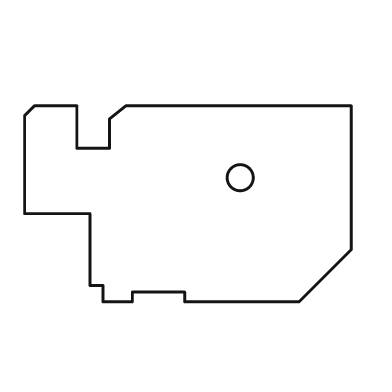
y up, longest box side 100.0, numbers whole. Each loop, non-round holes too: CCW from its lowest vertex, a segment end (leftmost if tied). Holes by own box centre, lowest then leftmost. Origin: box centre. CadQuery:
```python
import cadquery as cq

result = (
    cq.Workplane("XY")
    .moveTo(-26.0, -30.0)
    .lineTo(-17.0, -30.0)
    .lineTo(-17.0, -27.0)
    .lineTo(-1.0, -27.0)
    .lineTo(-1.0, -30.0)
    .lineTo(34.0, -30.0)
    .lineTo(50.0, -14.0)
    .lineTo(50.0, 30.0)
    .lineTo(-19.0, 30.0)
    .lineTo(-24.0, 26.0)
    .lineTo(-24.0, 17.0)
    .lineTo(-34.0, 17.0)
    .lineTo(-34.0, 30.0)
    .lineTo(-47.0, 30.0)
    .lineTo(-50.0, 27.0)
    .lineTo(-50.0, -3.0)
    .lineTo(-30.0, -3.0)
    .lineTo(-30.0, -25.0)
    .lineTo(-26.0, -25.0)
    .close()
    .moveTo(16.0, 8.0)
    .circle(4.0)
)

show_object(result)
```